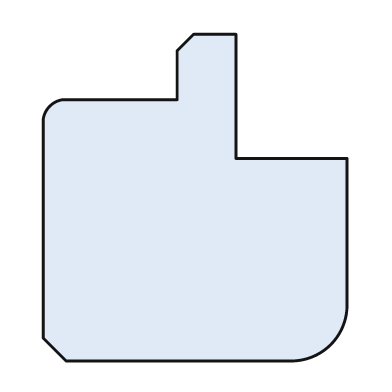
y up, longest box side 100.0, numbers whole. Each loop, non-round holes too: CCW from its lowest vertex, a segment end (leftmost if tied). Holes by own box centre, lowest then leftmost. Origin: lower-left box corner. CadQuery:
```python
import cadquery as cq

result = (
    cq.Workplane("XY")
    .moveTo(7.0, 0.0)
    .lineTo(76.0, 0.0)
    .threePointArc((88.0, 5.0), (93.0, 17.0))
    .lineTo(93.0, 62.0)
    .lineTo(59.0, 62.0)
    .lineTo(59.0, 100.0)
    .lineTo(46.0, 100.0)
    .lineTo(41.0, 95.0)
    .lineTo(41.0, 80.0)
    .lineTo(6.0, 80.0)
    .threePointArc((2.0, 78.0), (0.0, 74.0))
    .lineTo(0.0, 7.0)
    .close()
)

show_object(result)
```